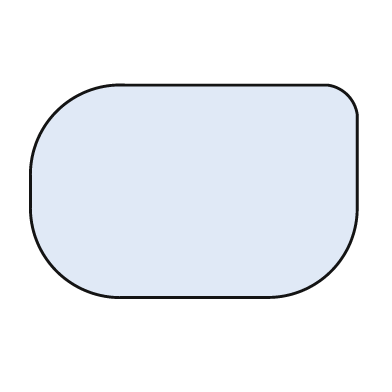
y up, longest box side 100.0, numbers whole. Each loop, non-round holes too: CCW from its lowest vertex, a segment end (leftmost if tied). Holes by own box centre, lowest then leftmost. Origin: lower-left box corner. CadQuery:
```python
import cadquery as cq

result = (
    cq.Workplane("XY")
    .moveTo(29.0, 0.0)
    .lineTo(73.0, 0.0)
    .threePointArc((92.0, 8.0), (100.0, 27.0))
    .lineTo(100.0, 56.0)
    .threePointArc((97.0, 62.0), (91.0, 65.0))
    .lineTo(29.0, 65.0)
    .threePointArc((8.0, 57.0), (0.0, 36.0))
    .lineTo(0.0, 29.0)
    .threePointArc((8.0, 8.0), (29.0, 0.0))
    .close()
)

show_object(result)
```